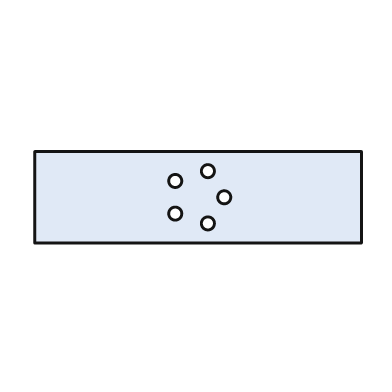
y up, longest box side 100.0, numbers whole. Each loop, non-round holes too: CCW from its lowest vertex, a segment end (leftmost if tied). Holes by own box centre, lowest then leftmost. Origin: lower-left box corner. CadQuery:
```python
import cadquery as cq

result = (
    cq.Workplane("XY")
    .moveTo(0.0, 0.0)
    .lineTo(100.0, 0.0)
    .lineTo(100.0, 28.0)
    .lineTo(0.0, 28.0)
    .close()
    .moveTo(53.0, 6.0)
    .circle(2.0)
    .moveTo(43.0, 9.0)
    .circle(2.0)
    .moveTo(58.0, 14.0)
    .circle(2.0)
    .moveTo(43.0, 19.0)
    .circle(2.0)
    .moveTo(53.0, 22.0)
    .circle(2.0)
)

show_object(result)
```